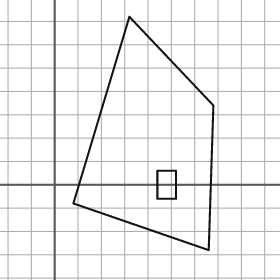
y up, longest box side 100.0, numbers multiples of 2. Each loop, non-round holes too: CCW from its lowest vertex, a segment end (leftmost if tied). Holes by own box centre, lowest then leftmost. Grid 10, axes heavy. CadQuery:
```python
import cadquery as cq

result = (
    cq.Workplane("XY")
    .moveTo(66.0, -28.0)
    .lineTo(68.0, 34.0)
    .lineTo(32.0, 72.0)
    .lineTo(8.0, -8.0)
    .close()
    .moveTo(44.0, -6.0)
    .lineTo(52.0, -6.0)
    .lineTo(52.0, 6.0)
    .lineTo(44.0, 6.0)
    .close()
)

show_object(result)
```